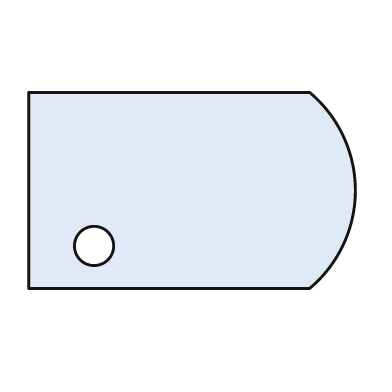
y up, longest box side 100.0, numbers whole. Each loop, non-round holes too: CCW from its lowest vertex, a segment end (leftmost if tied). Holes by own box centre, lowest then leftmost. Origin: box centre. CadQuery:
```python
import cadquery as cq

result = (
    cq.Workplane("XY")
    .moveTo(-50.0, -30.0)
    .lineTo(36.0, -30.0)
    .threePointArc((50.0, 0.0), (36.0, 30.0))
    .lineTo(-50.0, 30.0)
    .close()
    .moveTo(-30.0, -17.0)
    .circle(6.0)
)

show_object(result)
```